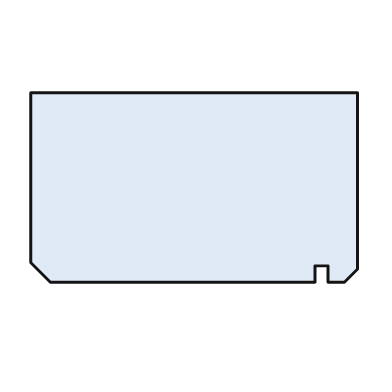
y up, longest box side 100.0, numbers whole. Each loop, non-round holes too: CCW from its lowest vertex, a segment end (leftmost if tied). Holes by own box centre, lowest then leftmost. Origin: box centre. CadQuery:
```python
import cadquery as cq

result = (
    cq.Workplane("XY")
    .moveTo(-44.0, -29.0)
    .lineTo(37.0, -29.0)
    .lineTo(37.0, -24.0)
    .lineTo(41.0, -24.0)
    .lineTo(41.0, -29.0)
    .lineTo(46.0, -29.0)
    .lineTo(50.0, -25.0)
    .lineTo(50.0, 29.0)
    .lineTo(-50.0, 29.0)
    .lineTo(-50.0, -23.0)
    .close()
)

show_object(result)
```